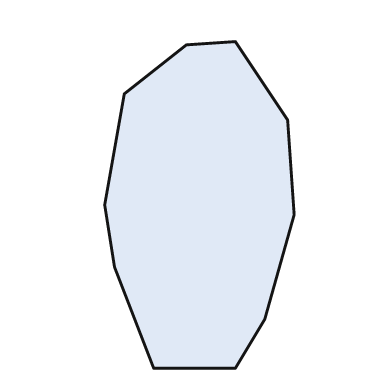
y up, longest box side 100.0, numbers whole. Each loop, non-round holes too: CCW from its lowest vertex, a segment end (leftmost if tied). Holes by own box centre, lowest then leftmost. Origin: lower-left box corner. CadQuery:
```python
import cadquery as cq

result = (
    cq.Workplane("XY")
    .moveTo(15.0, 0.0)
    .lineTo(40.0, 0.0)
    .lineTo(49.0, 15.0)
    .lineTo(58.0, 47.0)
    .lineTo(56.0, 76.0)
    .lineTo(40.0, 100.0)
    .lineTo(25.0, 99.0)
    .lineTo(6.0, 84.0)
    .lineTo(0.0, 50.0)
    .lineTo(3.0, 31.0)
    .close()
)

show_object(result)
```